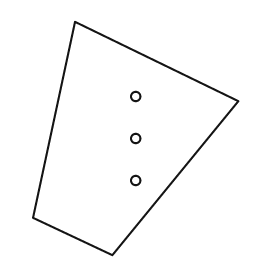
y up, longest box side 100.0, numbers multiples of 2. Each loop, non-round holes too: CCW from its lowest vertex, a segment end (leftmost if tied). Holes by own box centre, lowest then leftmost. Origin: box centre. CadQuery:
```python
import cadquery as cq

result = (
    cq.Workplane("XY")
    .moveTo(-10.0, -50.0)
    .lineTo(44.0, 16.0)
    .lineTo(-26.0, 50.0)
    .lineTo(-44.0, -34.0)
    .close()
    .moveTo(0.0, -18.0)
    .circle(2.0)
    .moveTo(0.0, 0.0)
    .circle(2.0)
    .moveTo(0.0, 18.0)
    .circle(2.0)
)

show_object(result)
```